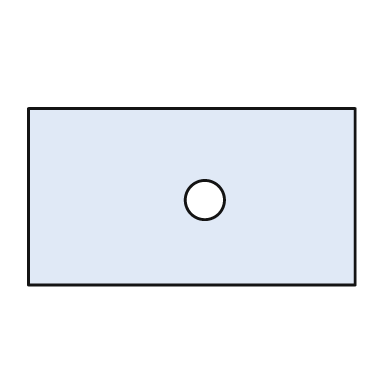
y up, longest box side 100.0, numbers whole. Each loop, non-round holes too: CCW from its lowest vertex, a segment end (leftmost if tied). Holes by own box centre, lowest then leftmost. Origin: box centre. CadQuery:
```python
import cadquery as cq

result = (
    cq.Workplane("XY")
    .moveTo(-50.0, -27.0)
    .lineTo(50.0, -27.0)
    .lineTo(50.0, 27.0)
    .lineTo(-50.0, 27.0)
    .close()
    .moveTo(4.0, -1.0)
    .circle(6.0)
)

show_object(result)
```